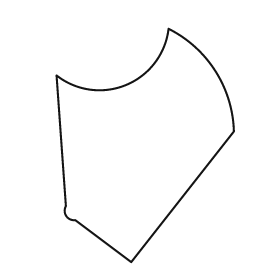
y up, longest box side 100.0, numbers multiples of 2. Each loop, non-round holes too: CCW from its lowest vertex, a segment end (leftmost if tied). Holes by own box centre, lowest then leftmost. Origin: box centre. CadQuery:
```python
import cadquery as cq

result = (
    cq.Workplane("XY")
    .moveTo(-6.0, -50.0)
    .lineTo(38.0, 6.0)
    .threePointArc((30.0, 32.0), (10.0, 50.0))
    .threePointArc((-8.0, 26.0), (-38.0, 30.0))
    .lineTo(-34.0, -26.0)
    .threePointArc((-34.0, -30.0), (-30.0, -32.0))
    .close()
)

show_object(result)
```